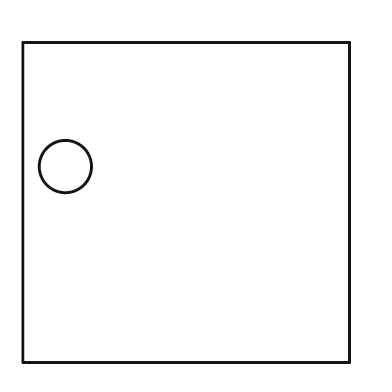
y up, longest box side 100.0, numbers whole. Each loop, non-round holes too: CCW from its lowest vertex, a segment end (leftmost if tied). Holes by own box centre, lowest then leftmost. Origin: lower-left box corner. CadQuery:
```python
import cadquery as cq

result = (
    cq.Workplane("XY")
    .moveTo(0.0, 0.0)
    .lineTo(100.0, 0.0)
    .lineTo(100.0, 98.0)
    .lineTo(0.0, 98.0)
    .close()
    .moveTo(13.0, 60.0)
    .circle(8.0)
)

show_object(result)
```